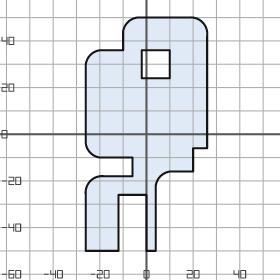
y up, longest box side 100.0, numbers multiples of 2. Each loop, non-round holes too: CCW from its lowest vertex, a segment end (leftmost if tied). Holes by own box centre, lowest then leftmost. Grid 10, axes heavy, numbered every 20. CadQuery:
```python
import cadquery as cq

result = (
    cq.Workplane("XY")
    .moveTo(-26.0, -50.0)
    .lineTo(-12.0, -50.0)
    .lineTo(-12.0, -26.0)
    .lineTo(0.0, -26.0)
    .lineTo(0.0, -50.0)
    .lineTo(4.0, -50.0)
    .lineTo(4.0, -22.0)
    .threePointArc((6.0, -18.0), (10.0, -16.0))
    .lineTo(20.0, -16.0)
    .lineTo(20.0, -6.0)
    .lineTo(26.0, -6.0)
    .lineTo(26.0, 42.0)
    .threePointArc((24.0, 48.0), (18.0, 50.0))
    .lineTo(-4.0, 50.0)
    .threePointArc((-8.0, 48.0), (-10.0, 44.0))
    .lineTo(-10.0, 36.0)
    .lineTo(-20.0, 36.0)
    .threePointArc((-24.0, 34.0), (-26.0, 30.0))
    .lineTo(-26.0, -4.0)
    .threePointArc((-24.0, -8.0), (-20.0, -10.0))
    .lineTo(-6.0, -10.0)
    .lineTo(-6.0, -18.0)
    .lineTo(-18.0, -18.0)
    .threePointArc((-24.0, -20.0), (-26.0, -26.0))
    .close()
    .moveTo(-2.0, 24.0)
    .lineTo(10.0, 24.0)
    .lineTo(10.0, 36.0)
    .lineTo(-2.0, 36.0)
    .close()
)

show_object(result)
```